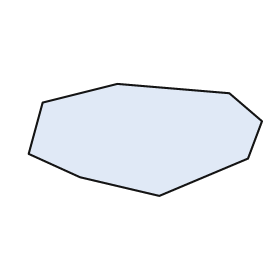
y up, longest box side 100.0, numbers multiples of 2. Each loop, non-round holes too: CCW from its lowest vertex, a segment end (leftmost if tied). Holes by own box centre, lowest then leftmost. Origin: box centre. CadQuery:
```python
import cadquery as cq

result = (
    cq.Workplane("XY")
    .moveTo(6.0, -24.0)
    .lineTo(44.0, -8.0)
    .lineTo(50.0, 8.0)
    .lineTo(36.0, 20.0)
    .lineTo(-12.0, 24.0)
    .lineTo(-44.0, 16.0)
    .lineTo(-50.0, -6.0)
    .lineTo(-28.0, -16.0)
    .close()
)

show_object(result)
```